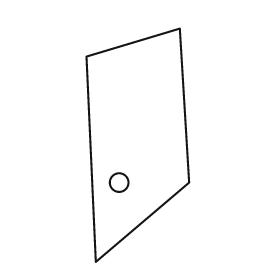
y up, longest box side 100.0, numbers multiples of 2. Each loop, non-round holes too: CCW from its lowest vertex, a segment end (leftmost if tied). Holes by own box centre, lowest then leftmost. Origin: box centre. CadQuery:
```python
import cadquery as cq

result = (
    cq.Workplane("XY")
    .moveTo(-18.0, -50.0)
    .lineTo(22.0, -16.0)
    .lineTo(18.0, 50.0)
    .lineTo(-22.0, 38.0)
    .close()
    .moveTo(-8.0, -16.0)
    .circle(4.0)
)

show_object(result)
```